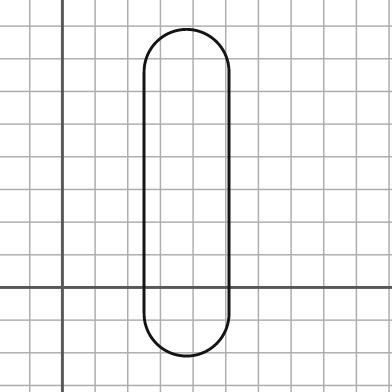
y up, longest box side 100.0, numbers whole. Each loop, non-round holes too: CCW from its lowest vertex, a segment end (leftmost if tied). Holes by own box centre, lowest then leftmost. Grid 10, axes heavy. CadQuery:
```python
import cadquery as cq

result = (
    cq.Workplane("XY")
    .moveTo(25.0, -8.0)
    .threePointArc((38.0, -21.0), (51.0, -8.0))
    .lineTo(51.0, 66.0)
    .threePointArc((38.0, 79.0), (25.0, 66.0))
    .close()
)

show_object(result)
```